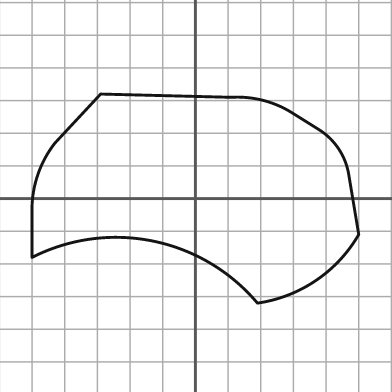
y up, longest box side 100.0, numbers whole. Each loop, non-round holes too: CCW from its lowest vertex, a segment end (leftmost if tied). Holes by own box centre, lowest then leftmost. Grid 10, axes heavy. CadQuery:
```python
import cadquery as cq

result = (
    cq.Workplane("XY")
    .moveTo(19.0, -32.0)
    .threePointArc((37.0, -25.0), (50.0, -11.0))
    .lineTo(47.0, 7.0)
    .threePointArc((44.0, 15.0), (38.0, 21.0))
    .lineTo(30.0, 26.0)
    .threePointArc((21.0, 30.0), (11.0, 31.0))
    .lineTo(-29.0, 32.0)
    .lineTo(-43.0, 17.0)
    .threePointArc((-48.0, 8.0), (-50.0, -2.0))
    .lineTo(-50.0, -18.0)
    .threePointArc((-13.0, -13.0), (19.0, -32.0))
    .close()
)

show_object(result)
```